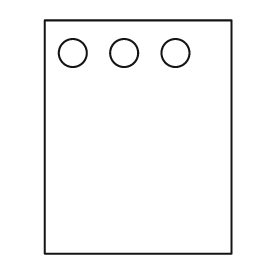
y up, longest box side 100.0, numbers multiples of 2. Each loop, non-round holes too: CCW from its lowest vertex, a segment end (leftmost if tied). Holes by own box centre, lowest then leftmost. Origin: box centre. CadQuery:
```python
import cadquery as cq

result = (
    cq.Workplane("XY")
    .moveTo(-40.0, -50.0)
    .lineTo(40.0, -50.0)
    .lineTo(40.0, 50.0)
    .lineTo(-40.0, 50.0)
    .close()
    .moveTo(-28.0, 36.0)
    .circle(6.0)
    .moveTo(-6.0, 36.0)
    .circle(6.0)
    .moveTo(16.0, 36.0)
    .circle(6.0)
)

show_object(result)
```